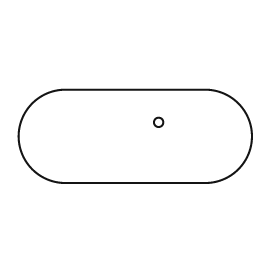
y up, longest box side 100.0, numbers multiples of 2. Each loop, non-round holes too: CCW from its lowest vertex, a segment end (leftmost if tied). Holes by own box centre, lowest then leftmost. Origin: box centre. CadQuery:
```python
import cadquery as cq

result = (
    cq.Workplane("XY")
    .moveTo(-30.0, -20.0)
    .lineTo(30.0, -20.0)
    .threePointArc((50.0, 0.0), (30.0, 20.0))
    .lineTo(-30.0, 20.0)
    .threePointArc((-50.0, 0.0), (-30.0, -20.0))
    .close()
    .moveTo(10.0, 6.0)
    .circle(2.0)
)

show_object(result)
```